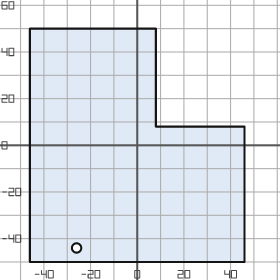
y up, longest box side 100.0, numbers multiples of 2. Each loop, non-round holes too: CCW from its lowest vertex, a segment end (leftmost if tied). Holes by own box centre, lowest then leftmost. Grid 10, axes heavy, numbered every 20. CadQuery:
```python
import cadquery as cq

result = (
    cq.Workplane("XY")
    .moveTo(-46.0, -50.0)
    .lineTo(46.0, -50.0)
    .lineTo(46.0, 8.0)
    .lineTo(8.0, 8.0)
    .lineTo(8.0, 50.0)
    .lineTo(-46.0, 50.0)
    .close()
    .moveTo(-26.0, -44.0)
    .circle(2.0)
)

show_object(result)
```